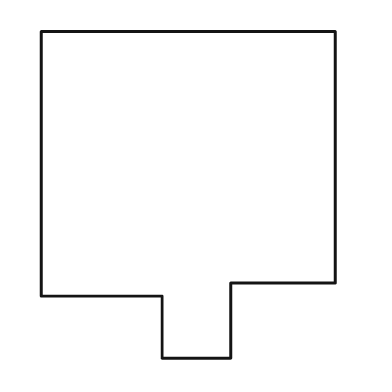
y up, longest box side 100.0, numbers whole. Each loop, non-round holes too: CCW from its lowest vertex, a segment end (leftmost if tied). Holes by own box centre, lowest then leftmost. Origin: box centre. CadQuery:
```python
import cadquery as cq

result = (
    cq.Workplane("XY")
    .moveTo(-8.0, -50.0)
    .lineTo(13.0, -50.0)
    .lineTo(13.0, -27.0)
    .lineTo(45.0, -27.0)
    .lineTo(45.0, 50.0)
    .lineTo(-45.0, 50.0)
    .lineTo(-45.0, -31.0)
    .lineTo(-8.0, -31.0)
    .close()
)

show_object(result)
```